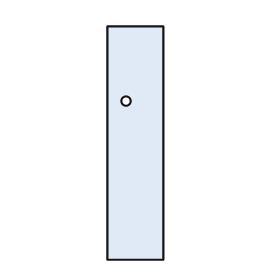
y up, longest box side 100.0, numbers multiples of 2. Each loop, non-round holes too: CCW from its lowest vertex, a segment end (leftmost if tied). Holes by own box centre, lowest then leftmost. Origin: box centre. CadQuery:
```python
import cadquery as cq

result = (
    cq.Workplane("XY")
    .moveTo(-12.0, -50.0)
    .lineTo(12.0, -50.0)
    .lineTo(12.0, 50.0)
    .lineTo(-12.0, 50.0)
    .close()
    .moveTo(-4.0, 18.0)
    .circle(2.0)
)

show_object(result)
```